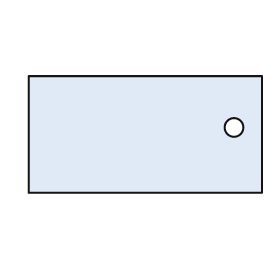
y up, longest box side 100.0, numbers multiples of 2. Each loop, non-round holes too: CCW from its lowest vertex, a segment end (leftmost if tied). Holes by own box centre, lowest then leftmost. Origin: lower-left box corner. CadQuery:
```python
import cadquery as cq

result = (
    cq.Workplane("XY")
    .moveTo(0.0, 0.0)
    .lineTo(100.0, 0.0)
    .lineTo(100.0, 50.0)
    .lineTo(0.0, 50.0)
    .close()
    .moveTo(88.0, 28.0)
    .circle(4.0)
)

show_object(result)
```